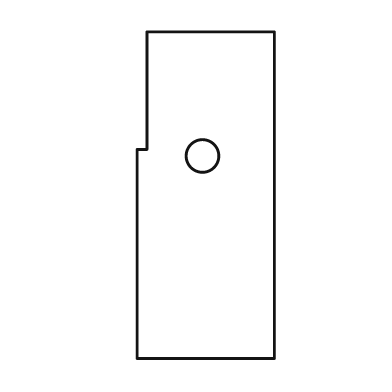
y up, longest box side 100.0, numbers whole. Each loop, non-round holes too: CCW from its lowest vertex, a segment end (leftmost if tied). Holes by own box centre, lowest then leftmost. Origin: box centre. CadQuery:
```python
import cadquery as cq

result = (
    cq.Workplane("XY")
    .moveTo(-21.0, -50.0)
    .lineTo(21.0, -50.0)
    .lineTo(21.0, 50.0)
    .lineTo(-18.0, 50.0)
    .lineTo(-18.0, 14.0)
    .lineTo(-21.0, 14.0)
    .close()
    .moveTo(-1.0, 12.0)
    .circle(5.0)
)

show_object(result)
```